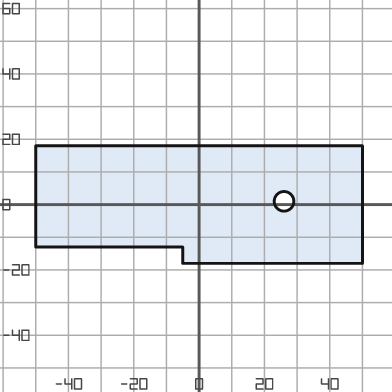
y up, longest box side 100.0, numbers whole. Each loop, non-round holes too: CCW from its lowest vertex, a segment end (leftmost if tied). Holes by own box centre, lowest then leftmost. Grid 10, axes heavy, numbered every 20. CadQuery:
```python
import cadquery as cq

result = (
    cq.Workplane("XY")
    .moveTo(-5.0, -18.0)
    .lineTo(50.0, -18.0)
    .lineTo(50.0, 18.0)
    .lineTo(-50.0, 18.0)
    .lineTo(-50.0, -13.0)
    .lineTo(-5.0, -13.0)
    .close()
    .moveTo(26.0, 1.0)
    .circle(3.0)
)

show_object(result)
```